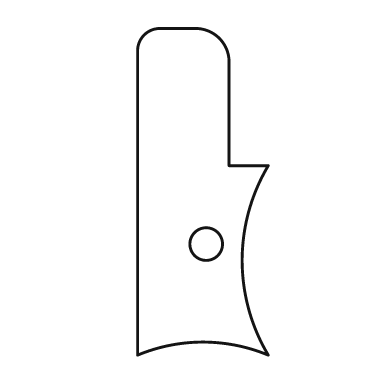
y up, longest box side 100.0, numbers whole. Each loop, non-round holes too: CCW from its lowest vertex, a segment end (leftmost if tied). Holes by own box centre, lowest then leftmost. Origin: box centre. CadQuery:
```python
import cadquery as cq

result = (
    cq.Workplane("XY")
    .moveTo(-20.0, -50.0)
    .threePointArc((0.0, -46.0), (20.0, -50.0))
    .threePointArc((12.0, -21.0), (20.0, 8.0))
    .lineTo(8.0, 8.0)
    .lineTo(8.0, 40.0)
    .threePointArc((5.0, 47.0), (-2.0, 50.0))
    .lineTo(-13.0, 50.0)
    .threePointArc((-18.0, 48.0), (-20.0, 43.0))
    .close()
    .moveTo(1.0, -16.0)
    .circle(5.0)
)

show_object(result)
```